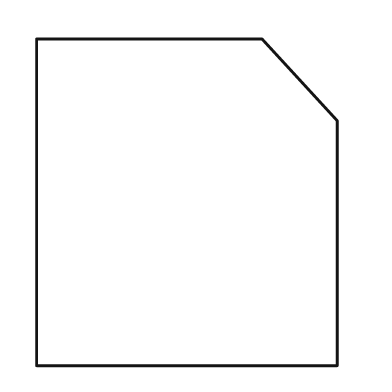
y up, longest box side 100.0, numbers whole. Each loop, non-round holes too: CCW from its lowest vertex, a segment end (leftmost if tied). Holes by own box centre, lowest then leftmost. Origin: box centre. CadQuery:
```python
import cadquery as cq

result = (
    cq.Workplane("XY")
    .moveTo(-46.0, -50.0)
    .lineTo(46.0, -50.0)
    .lineTo(46.0, 25.0)
    .lineTo(23.0, 50.0)
    .lineTo(-46.0, 50.0)
    .close()
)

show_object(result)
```